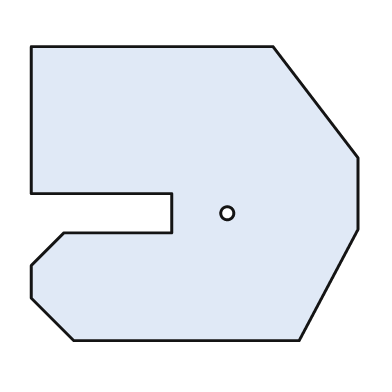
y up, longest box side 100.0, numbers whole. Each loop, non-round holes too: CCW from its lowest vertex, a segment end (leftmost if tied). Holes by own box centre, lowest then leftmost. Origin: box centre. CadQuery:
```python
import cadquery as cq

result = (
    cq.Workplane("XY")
    .moveTo(-37.0, -45.0)
    .lineTo(32.0, -45.0)
    .lineTo(50.0, -11.0)
    .lineTo(50.0, 11.0)
    .lineTo(24.0, 45.0)
    .lineTo(-50.0, 45.0)
    .lineTo(-50.0, 0.0)
    .lineTo(-7.0, 0.0)
    .lineTo(-7.0, -12.0)
    .lineTo(-40.0, -12.0)
    .lineTo(-50.0, -22.0)
    .lineTo(-50.0, -32.0)
    .close()
    .moveTo(10.0, -6.0)
    .circle(2.0)
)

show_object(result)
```